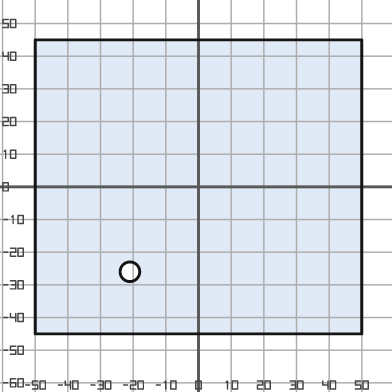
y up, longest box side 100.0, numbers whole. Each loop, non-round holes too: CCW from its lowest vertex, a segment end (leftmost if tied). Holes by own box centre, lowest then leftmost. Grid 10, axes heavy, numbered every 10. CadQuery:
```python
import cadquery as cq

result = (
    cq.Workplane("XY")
    .moveTo(-50.0, -45.0)
    .lineTo(50.0, -45.0)
    .lineTo(50.0, 45.0)
    .lineTo(-50.0, 45.0)
    .close()
    .moveTo(-21.0, -26.0)
    .circle(3.0)
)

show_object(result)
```